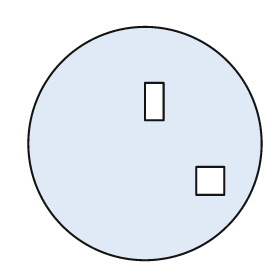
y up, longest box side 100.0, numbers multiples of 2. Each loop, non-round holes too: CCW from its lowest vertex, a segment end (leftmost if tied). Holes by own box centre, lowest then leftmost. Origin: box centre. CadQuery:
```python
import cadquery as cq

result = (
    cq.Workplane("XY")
    .moveTo(0.0, 0.0)
    .circle(50.0)
    .moveTo(22.0, -22.0)
    .lineTo(34.0, -22.0)
    .lineTo(34.0, -10.0)
    .lineTo(22.0, -10.0)
    .close()
    .moveTo(0.0, 10.0)
    .lineTo(8.0, 10.0)
    .lineTo(8.0, 26.0)
    .lineTo(0.0, 26.0)
    .close()
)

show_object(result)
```